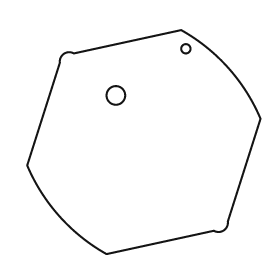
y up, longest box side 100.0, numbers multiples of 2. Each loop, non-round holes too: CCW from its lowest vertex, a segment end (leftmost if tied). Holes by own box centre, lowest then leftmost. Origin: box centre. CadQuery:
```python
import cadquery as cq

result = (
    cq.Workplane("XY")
    .moveTo(-16.0, -48.0)
    .lineTo(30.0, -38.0)
    .threePointArc((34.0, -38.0), (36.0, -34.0))
    .lineTo(50.0, 10.0)
    .threePointArc((36.0, 32.0), (16.0, 48.0))
    .lineTo(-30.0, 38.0)
    .threePointArc((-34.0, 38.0), (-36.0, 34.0))
    .lineTo(-50.0, -10.0)
    .threePointArc((-36.0, -32.0), (-16.0, -48.0))
    .close()
    .moveTo(-12.0, 20.0)
    .circle(4.0)
    .moveTo(18.0, 40.0)
    .circle(2.0)
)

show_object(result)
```